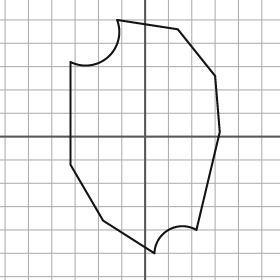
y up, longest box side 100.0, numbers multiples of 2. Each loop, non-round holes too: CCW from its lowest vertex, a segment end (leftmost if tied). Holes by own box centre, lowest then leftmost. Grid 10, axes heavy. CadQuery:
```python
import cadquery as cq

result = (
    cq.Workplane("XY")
    .moveTo(4.0, -50.0)
    .threePointArc((10.0, -40.0), (22.0, -40.0))
    .lineTo(32.0, 2.0)
    .lineTo(30.0, 26.0)
    .lineTo(14.0, 46.0)
    .lineTo(-12.0, 50.0)
    .threePointArc((-16.0, 34.0), (-32.0, 32.0))
    .lineTo(-32.0, -12.0)
    .lineTo(-18.0, -36.0)
    .close()
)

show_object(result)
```